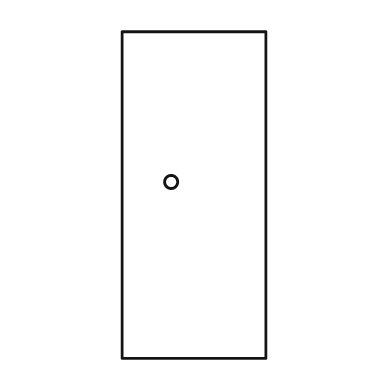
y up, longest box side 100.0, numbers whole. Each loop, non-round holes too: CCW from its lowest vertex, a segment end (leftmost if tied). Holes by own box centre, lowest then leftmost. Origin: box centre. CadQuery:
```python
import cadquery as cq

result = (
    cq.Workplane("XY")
    .moveTo(-22.0, -50.0)
    .lineTo(22.0, -50.0)
    .lineTo(22.0, 50.0)
    .lineTo(-22.0, 50.0)
    .close()
    .moveTo(-7.0, 4.0)
    .circle(2.0)
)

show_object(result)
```